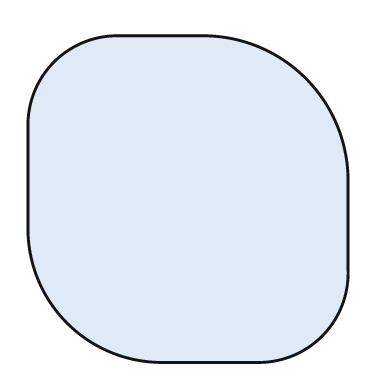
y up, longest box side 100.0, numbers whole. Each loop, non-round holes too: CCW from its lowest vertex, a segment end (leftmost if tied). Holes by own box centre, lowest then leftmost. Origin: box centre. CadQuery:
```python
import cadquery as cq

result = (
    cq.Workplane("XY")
    .moveTo(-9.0, -50.0)
    .lineTo(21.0, -50.0)
    .threePointArc((41.0, -42.0), (49.0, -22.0))
    .lineTo(49.0, 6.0)
    .threePointArc((36.0, 37.0), (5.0, 50.0))
    .lineTo(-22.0, 50.0)
    .threePointArc((-41.0, 42.0), (-49.0, 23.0))
    .lineTo(-49.0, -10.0)
    .threePointArc((-37.0, -38.0), (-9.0, -50.0))
    .close()
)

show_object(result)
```